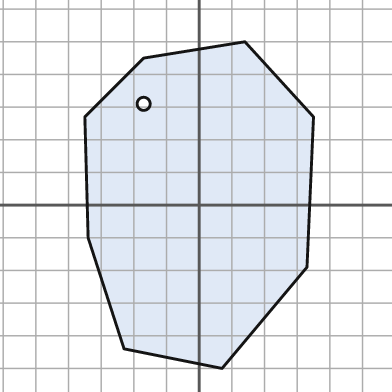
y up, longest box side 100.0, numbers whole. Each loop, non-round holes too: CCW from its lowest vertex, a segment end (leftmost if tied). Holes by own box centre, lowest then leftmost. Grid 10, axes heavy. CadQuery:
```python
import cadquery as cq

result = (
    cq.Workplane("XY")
    .moveTo(7.0, -50.0)
    .lineTo(33.0, -19.0)
    .lineTo(35.0, 27.0)
    .lineTo(14.0, 50.0)
    .lineTo(-17.0, 45.0)
    .lineTo(-35.0, 27.0)
    .lineTo(-34.0, -10.0)
    .lineTo(-23.0, -44.0)
    .close()
    .moveTo(-17.0, 31.0)
    .circle(2.0)
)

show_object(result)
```